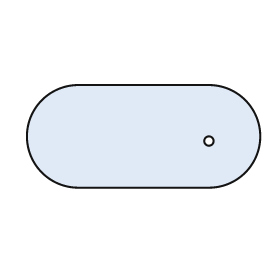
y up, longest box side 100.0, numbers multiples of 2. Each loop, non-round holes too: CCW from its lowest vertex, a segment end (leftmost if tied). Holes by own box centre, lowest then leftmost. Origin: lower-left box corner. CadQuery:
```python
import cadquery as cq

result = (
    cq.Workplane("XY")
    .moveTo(22.0, 0.0)
    .lineTo(78.0, 0.0)
    .threePointArc((100.0, 22.0), (78.0, 44.0))
    .lineTo(22.0, 44.0)
    .threePointArc((0.0, 22.0), (22.0, 0.0))
    .close()
    .moveTo(78.0, 20.0)
    .circle(2.0)
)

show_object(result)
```